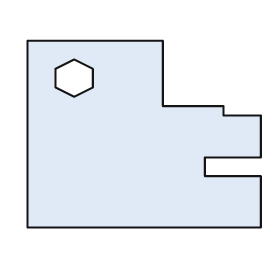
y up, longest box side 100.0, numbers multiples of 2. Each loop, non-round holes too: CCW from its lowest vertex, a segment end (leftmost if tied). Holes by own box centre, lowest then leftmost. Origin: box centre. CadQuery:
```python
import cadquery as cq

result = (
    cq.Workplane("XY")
    .moveTo(-50.0, -40.0)
    .lineTo(50.0, -40.0)
    .lineTo(50.0, -18.0)
    .lineTo(26.0, -18.0)
    .lineTo(26.0, -10.0)
    .lineTo(50.0, -10.0)
    .lineTo(50.0, 8.0)
    .lineTo(34.0, 8.0)
    .lineTo(34.0, 12.0)
    .lineTo(8.0, 12.0)
    .lineTo(8.0, 40.0)
    .lineTo(-50.0, 40.0)
    .close()
    .moveTo(-30.0, 16.0)
    .lineTo(-22.0, 20.0)
    .lineTo(-22.0, 28.0)
    .lineTo(-30.0, 32.0)
    .lineTo(-38.0, 28.0)
    .lineTo(-38.0, 20.0)
    .close()
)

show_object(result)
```